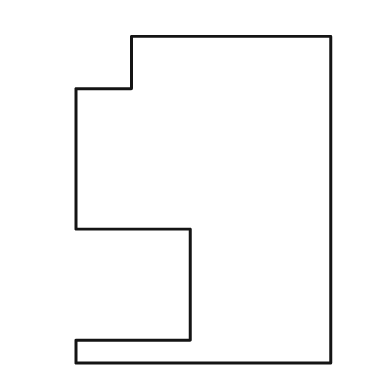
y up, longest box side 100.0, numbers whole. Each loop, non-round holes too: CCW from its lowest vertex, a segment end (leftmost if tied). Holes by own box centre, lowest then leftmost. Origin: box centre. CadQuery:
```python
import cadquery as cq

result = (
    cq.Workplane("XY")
    .moveTo(-39.0, -50.0)
    .lineTo(39.0, -50.0)
    .lineTo(39.0, 50.0)
    .lineTo(-22.0, 50.0)
    .lineTo(-22.0, 34.0)
    .lineTo(-39.0, 34.0)
    .lineTo(-39.0, -9.0)
    .lineTo(-4.0, -9.0)
    .lineTo(-4.0, -43.0)
    .lineTo(-39.0, -43.0)
    .close()
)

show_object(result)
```